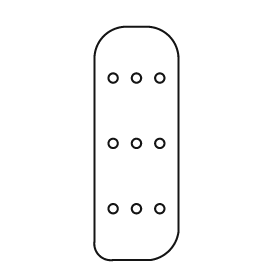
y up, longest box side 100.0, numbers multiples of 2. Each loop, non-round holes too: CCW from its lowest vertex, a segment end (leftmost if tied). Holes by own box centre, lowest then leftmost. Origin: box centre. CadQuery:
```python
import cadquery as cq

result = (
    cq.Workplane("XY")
    .moveTo(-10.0, -50.0)
    .lineTo(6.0, -50.0)
    .threePointArc((14.0, -46.0), (18.0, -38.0))
    .lineTo(18.0, 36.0)
    .threePointArc((14.0, 46.0), (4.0, 50.0))
    .lineTo(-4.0, 50.0)
    .threePointArc((-14.0, 46.0), (-18.0, 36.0))
    .lineTo(-18.0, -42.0)
    .threePointArc((-16.0, -48.0), (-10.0, -50.0))
    .close()
    .moveTo(-10.0, -28.0)
    .circle(2.0)
    .moveTo(0.0, -28.0)
    .circle(2.0)
    .moveTo(10.0, -28.0)
    .circle(2.0)
    .moveTo(-10.0, 0.0)
    .circle(2.0)
    .moveTo(0.0, 0.0)
    .circle(2.0)
    .moveTo(10.0, 0.0)
    .circle(2.0)
    .moveTo(-10.0, 28.0)
    .circle(2.0)
    .moveTo(0.0, 28.0)
    .circle(2.0)
    .moveTo(10.0, 28.0)
    .circle(2.0)
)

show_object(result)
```